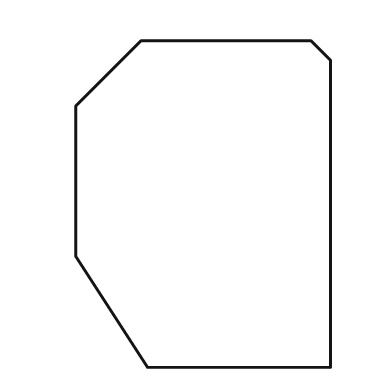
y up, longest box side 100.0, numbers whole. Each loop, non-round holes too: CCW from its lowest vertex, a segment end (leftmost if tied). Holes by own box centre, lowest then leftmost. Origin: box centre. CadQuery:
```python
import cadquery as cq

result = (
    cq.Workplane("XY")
    .moveTo(-17.0, -50.0)
    .lineTo(39.0, -50.0)
    .lineTo(39.0, 44.0)
    .lineTo(33.0, 50.0)
    .lineTo(-19.0, 50.0)
    .lineTo(-39.0, 30.0)
    .lineTo(-39.0, -16.0)
    .close()
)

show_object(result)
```